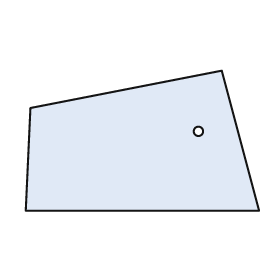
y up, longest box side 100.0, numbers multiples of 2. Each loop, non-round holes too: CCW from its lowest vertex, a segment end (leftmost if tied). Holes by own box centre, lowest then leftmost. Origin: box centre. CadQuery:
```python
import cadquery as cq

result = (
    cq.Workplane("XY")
    .moveTo(-50.0, -30.0)
    .lineTo(50.0, -30.0)
    .lineTo(34.0, 30.0)
    .lineTo(-48.0, 14.0)
    .close()
    .moveTo(24.0, 4.0)
    .circle(2.0)
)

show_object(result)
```